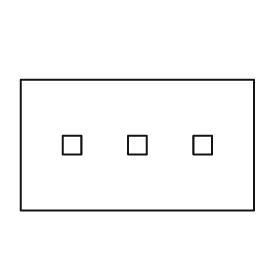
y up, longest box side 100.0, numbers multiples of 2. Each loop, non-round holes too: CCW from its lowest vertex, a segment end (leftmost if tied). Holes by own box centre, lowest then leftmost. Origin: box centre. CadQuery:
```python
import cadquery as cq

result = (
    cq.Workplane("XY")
    .moveTo(-50.0, -28.0)
    .lineTo(50.0, -28.0)
    .lineTo(50.0, 28.0)
    .lineTo(-50.0, 28.0)
    .close()
    .moveTo(-32.0, -4.0)
    .lineTo(-24.0, -4.0)
    .lineTo(-24.0, 4.0)
    .lineTo(-32.0, 4.0)
    .close()
    .moveTo(-4.0, -4.0)
    .lineTo(4.0, -4.0)
    .lineTo(4.0, 4.0)
    .lineTo(-4.0, 4.0)
    .close()
    .moveTo(24.0, -4.0)
    .lineTo(32.0, -4.0)
    .lineTo(32.0, 4.0)
    .lineTo(24.0, 4.0)
    .close()
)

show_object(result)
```